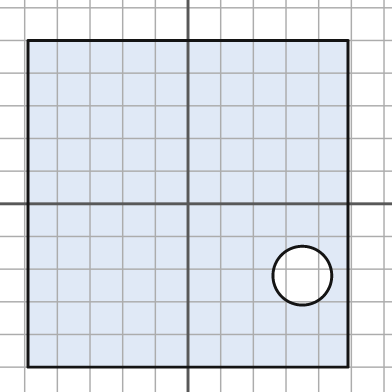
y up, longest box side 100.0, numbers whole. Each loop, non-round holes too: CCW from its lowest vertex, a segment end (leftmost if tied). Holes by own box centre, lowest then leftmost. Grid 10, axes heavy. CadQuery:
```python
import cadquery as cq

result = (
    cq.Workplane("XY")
    .moveTo(-49.0, -50.0)
    .lineTo(49.0, -50.0)
    .lineTo(49.0, 50.0)
    .lineTo(-49.0, 50.0)
    .close()
    .moveTo(35.0, -22.0)
    .circle(9.0)
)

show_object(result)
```